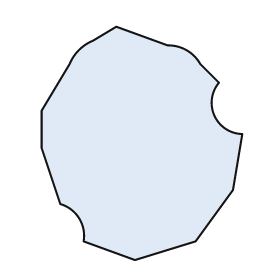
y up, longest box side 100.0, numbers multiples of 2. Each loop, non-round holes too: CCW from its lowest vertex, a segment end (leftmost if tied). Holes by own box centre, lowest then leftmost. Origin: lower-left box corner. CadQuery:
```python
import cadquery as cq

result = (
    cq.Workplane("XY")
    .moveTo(40.0, 0.0)
    .lineTo(66.0, 8.0)
    .lineTo(82.0, 30.0)
    .lineTo(86.0, 54.0)
    .threePointArc((74.0, 62.0), (76.0, 76.0))
    .lineTo(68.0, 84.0)
    .threePointArc((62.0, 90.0), (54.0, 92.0))
    .lineTo(32.0, 100.0)
    .lineTo(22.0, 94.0)
    .threePointArc((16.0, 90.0), (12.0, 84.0))
    .lineTo(0.0, 64.0)
    .lineTo(0.0, 48.0)
    .lineTo(8.0, 24.0)
    .threePointArc((16.0, 18.0), (18.0, 8.0))
    .close()
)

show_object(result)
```